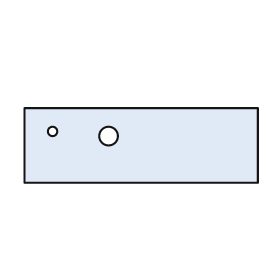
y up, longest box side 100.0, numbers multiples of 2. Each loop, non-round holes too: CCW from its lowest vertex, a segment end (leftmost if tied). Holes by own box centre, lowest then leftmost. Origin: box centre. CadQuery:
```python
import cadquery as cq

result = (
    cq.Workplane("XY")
    .moveTo(-50.0, -16.0)
    .lineTo(50.0, -16.0)
    .lineTo(50.0, 16.0)
    .lineTo(-50.0, 16.0)
    .close()
    .moveTo(-14.0, 4.0)
    .circle(4.0)
    .moveTo(-38.0, 6.0)
    .circle(2.0)
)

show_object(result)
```